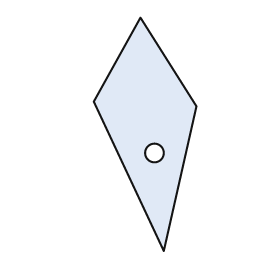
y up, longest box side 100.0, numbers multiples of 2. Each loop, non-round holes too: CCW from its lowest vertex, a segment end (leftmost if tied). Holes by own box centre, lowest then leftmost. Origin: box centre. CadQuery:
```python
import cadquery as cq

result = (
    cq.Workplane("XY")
    .moveTo(8.0, -50.0)
    .lineTo(22.0, 12.0)
    .lineTo(-2.0, 50.0)
    .lineTo(-22.0, 14.0)
    .close()
    .moveTo(4.0, -8.0)
    .circle(4.0)
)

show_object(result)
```